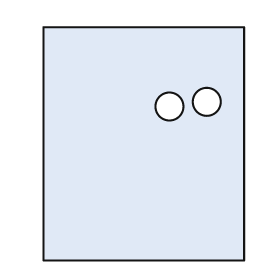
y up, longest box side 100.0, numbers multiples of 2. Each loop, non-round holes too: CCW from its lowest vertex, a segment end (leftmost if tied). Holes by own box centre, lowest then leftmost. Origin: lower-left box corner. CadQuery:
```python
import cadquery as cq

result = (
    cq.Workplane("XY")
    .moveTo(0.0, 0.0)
    .lineTo(86.0, 0.0)
    .lineTo(86.0, 100.0)
    .lineTo(0.0, 100.0)
    .close()
    .moveTo(54.0, 66.0)
    .circle(6.0)
    .moveTo(70.0, 68.0)
    .circle(6.0)
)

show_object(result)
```